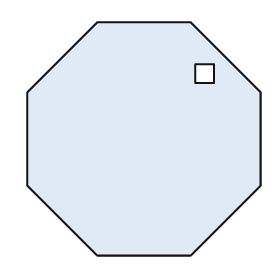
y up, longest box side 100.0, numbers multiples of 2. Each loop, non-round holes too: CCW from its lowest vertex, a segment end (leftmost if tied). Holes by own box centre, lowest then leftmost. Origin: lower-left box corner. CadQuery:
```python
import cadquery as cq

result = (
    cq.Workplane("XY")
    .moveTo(30.0, 0.0)
    .lineTo(70.0, 0.0)
    .lineTo(100.0, 30.0)
    .lineTo(100.0, 70.0)
    .lineTo(70.0, 100.0)
    .lineTo(30.0, 100.0)
    .lineTo(0.0, 70.0)
    .lineTo(0.0, 30.0)
    .close()
    .moveTo(72.0, 74.0)
    .lineTo(80.0, 74.0)
    .lineTo(80.0, 82.0)
    .lineTo(72.0, 82.0)
    .close()
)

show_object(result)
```